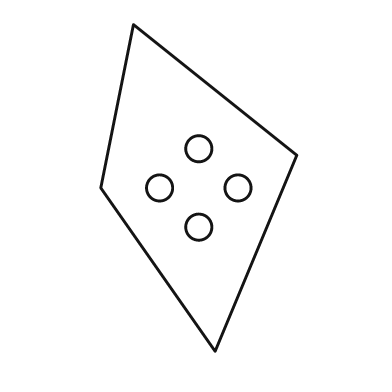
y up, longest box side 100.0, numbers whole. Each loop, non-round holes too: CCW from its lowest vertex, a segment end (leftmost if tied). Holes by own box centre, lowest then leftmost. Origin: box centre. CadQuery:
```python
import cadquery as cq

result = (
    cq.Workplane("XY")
    .moveTo(5.0, -50.0)
    .lineTo(30.0, 10.0)
    .lineTo(-20.0, 50.0)
    .lineTo(-30.0, 0.0)
    .close()
    .moveTo(0.0, -12.0)
    .circle(4.0)
    .moveTo(-12.0, 0.0)
    .circle(4.0)
    .moveTo(12.0, 0.0)
    .circle(4.0)
    .moveTo(0.0, 12.0)
    .circle(4.0)
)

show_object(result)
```